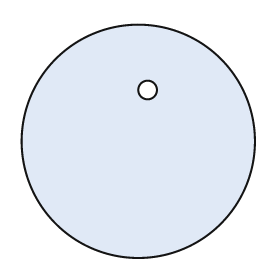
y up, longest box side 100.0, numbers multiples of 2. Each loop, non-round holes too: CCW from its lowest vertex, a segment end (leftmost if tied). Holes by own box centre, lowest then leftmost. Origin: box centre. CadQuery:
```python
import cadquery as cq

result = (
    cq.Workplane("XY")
    .moveTo(0.0, 0.0)
    .circle(50.0)
    .moveTo(4.0, 22.0)
    .circle(4.0)
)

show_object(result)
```